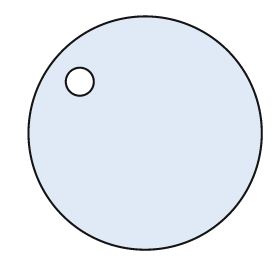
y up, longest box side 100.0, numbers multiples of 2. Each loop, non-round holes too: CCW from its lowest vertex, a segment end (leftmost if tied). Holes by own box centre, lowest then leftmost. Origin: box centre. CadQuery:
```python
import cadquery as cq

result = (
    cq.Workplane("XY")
    .moveTo(0.0, 0.0)
    .circle(50.0)
    .moveTo(-28.0, 22.0)
    .circle(6.0)
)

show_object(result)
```